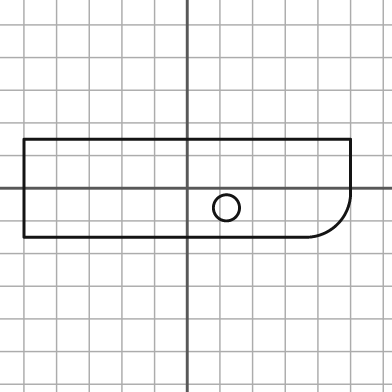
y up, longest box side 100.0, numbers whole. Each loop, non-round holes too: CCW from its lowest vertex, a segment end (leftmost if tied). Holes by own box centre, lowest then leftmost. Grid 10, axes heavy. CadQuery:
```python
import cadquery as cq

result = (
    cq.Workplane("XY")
    .moveTo(-50.0, -15.0)
    .lineTo(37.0, -15.0)
    .threePointArc((46.0, -11.0), (50.0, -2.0))
    .lineTo(50.0, 15.0)
    .lineTo(-50.0, 15.0)
    .close()
    .moveTo(12.0, -6.0)
    .circle(4.0)
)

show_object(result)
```